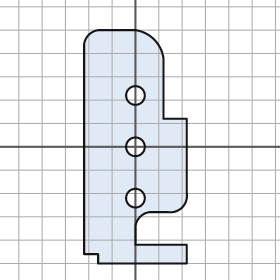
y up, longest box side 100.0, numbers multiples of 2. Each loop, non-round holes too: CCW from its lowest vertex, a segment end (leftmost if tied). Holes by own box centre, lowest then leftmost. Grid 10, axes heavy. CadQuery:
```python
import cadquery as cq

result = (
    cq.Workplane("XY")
    .moveTo(-16.0, -50.0)
    .lineTo(22.0, -50.0)
    .lineTo(22.0, -42.0)
    .lineTo(0.0, -42.0)
    .lineTo(0.0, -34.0)
    .threePointArc((2.0, -30.0), (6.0, -28.0))
    .lineTo(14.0, -28.0)
    .threePointArc((20.0, -26.0), (22.0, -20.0))
    .lineTo(22.0, 12.0)
    .lineTo(12.0, 12.0)
    .lineTo(12.0, 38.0)
    .threePointArc((8.0, 46.0), (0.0, 50.0))
    .lineTo(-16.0, 50.0)
    .threePointArc((-20.0, 48.0), (-22.0, 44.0))
    .lineTo(-22.0, -46.0)
    .lineTo(-16.0, -46.0)
    .close()
    .moveTo(0.0, -22.0)
    .circle(4.0)
    .moveTo(0.0, 0.0)
    .circle(4.0)
    .moveTo(0.0, 22.0)
    .circle(4.0)
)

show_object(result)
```